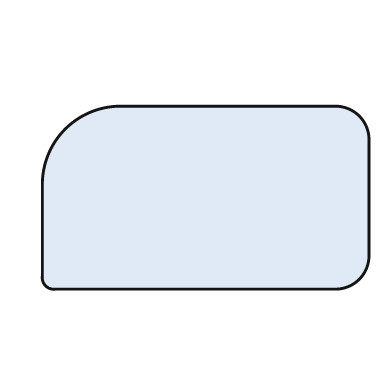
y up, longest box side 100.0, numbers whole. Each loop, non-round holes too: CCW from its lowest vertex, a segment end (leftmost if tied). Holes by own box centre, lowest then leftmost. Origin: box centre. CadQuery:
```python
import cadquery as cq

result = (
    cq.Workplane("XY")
    .moveTo(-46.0, -28.0)
    .lineTo(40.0, -28.0)
    .threePointArc((47.0, -25.0), (50.0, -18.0))
    .lineTo(50.0, 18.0)
    .threePointArc((47.0, 25.0), (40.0, 28.0))
    .lineTo(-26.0, 28.0)
    .threePointArc((-43.0, 21.0), (-50.0, 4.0))
    .lineTo(-50.0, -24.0)
    .threePointArc((-49.0, -27.0), (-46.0, -28.0))
    .close()
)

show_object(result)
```